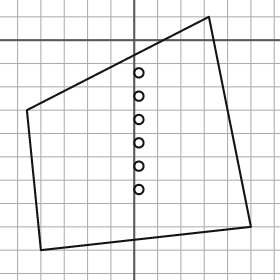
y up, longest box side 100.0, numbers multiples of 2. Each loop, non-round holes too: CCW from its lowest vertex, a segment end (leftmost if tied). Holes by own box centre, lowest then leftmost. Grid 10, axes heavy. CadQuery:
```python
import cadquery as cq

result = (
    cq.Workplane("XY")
    .moveTo(-40.0, -90.0)
    .lineTo(50.0, -80.0)
    .lineTo(32.0, 10.0)
    .lineTo(-46.0, -30.0)
    .close()
    .moveTo(2.0, -64.0)
    .circle(2.0)
    .moveTo(2.0, -54.0)
    .circle(2.0)
    .moveTo(2.0, -44.0)
    .circle(2.0)
    .moveTo(2.0, -34.0)
    .circle(2.0)
    .moveTo(2.0, -24.0)
    .circle(2.0)
    .moveTo(2.0, -14.0)
    .circle(2.0)
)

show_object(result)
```